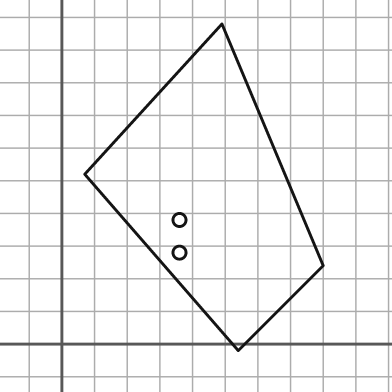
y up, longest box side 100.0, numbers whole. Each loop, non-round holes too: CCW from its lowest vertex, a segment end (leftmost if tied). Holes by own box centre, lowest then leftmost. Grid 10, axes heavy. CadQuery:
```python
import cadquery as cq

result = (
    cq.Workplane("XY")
    .moveTo(54.0, -2.0)
    .lineTo(80.0, 24.0)
    .lineTo(49.0, 98.0)
    .lineTo(7.0, 52.0)
    .close()
    .moveTo(36.0, 28.0)
    .circle(2.0)
    .moveTo(36.0, 38.0)
    .circle(2.0)
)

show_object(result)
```